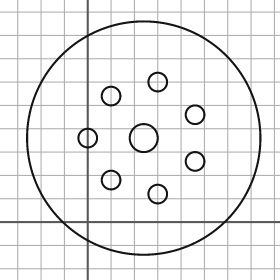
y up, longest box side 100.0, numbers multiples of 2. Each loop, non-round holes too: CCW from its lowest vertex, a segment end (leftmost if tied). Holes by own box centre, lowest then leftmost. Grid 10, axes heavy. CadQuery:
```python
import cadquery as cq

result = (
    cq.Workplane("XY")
    .moveTo(24.0, 36.0)
    .circle(50.0)
    .moveTo(30.0, 12.0)
    .circle(4.0)
    .moveTo(10.0, 18.0)
    .circle(4.0)
    .moveTo(46.0, 26.0)
    .circle(4.0)
    .moveTo(0.0, 36.0)
    .circle(4.0)
    .moveTo(24.0, 36.0)
    .circle(6.0)
    .moveTo(46.0, 46.0)
    .circle(4.0)
    .moveTo(10.0, 54.0)
    .circle(4.0)
    .moveTo(30.0, 60.0)
    .circle(4.0)
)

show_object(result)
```